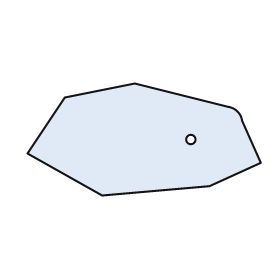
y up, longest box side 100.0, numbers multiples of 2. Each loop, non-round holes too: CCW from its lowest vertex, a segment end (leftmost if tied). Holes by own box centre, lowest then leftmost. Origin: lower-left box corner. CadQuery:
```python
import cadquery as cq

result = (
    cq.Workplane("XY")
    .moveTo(32.0, 0.0)
    .lineTo(78.0, 4.0)
    .lineTo(100.0, 14.0)
    .lineTo(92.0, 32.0)
    .threePointArc((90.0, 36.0), (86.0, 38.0))
    .lineTo(46.0, 48.0)
    .lineTo(16.0, 42.0)
    .lineTo(0.0, 18.0)
    .close()
    .moveTo(70.0, 24.0)
    .circle(2.0)
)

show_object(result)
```